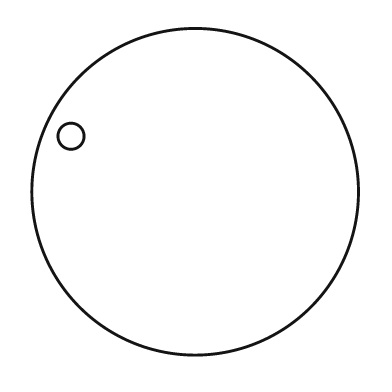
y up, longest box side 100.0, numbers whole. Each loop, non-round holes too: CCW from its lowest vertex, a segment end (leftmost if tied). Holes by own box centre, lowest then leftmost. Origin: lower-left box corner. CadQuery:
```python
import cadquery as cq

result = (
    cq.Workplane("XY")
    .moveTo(50.0, 50.0)
    .circle(50.0)
    .moveTo(12.0, 67.0)
    .circle(4.0)
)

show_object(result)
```